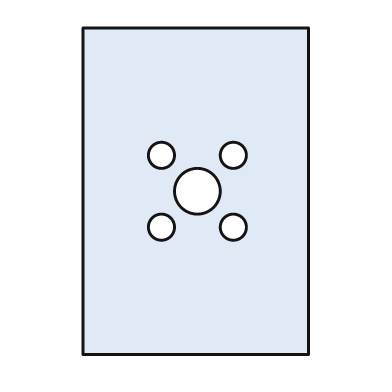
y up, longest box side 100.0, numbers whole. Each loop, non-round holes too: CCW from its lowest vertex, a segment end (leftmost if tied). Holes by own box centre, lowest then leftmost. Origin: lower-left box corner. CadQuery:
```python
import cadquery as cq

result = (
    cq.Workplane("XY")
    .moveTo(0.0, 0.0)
    .lineTo(69.0, 0.0)
    .lineTo(69.0, 100.0)
    .lineTo(0.0, 100.0)
    .close()
    .moveTo(24.0, 39.0)
    .circle(4.0)
    .moveTo(46.0, 39.0)
    .circle(4.0)
    .moveTo(35.0, 50.0)
    .circle(7.0)
    .moveTo(24.0, 61.0)
    .circle(4.0)
    .moveTo(46.0, 61.0)
    .circle(4.0)
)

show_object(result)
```